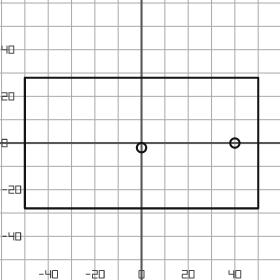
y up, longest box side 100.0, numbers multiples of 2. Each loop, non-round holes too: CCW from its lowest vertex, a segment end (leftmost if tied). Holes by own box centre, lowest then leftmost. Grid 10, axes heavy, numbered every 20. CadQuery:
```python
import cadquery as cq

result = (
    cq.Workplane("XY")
    .moveTo(-50.0, -28.0)
    .lineTo(50.0, -28.0)
    .lineTo(50.0, 28.0)
    .lineTo(-50.0, 28.0)
    .close()
    .moveTo(0.0, -2.0)
    .circle(2.0)
    .moveTo(40.0, 0.0)
    .circle(2.0)
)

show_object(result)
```